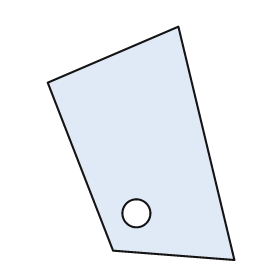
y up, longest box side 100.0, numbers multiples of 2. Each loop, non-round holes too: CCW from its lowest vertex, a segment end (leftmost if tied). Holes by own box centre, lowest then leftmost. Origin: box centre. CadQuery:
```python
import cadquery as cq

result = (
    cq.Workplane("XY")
    .moveTo(40.0, -50.0)
    .lineTo(16.0, 50.0)
    .lineTo(-40.0, 26.0)
    .lineTo(-12.0, -46.0)
    .close()
    .moveTo(-2.0, -30.0)
    .circle(6.0)
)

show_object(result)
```